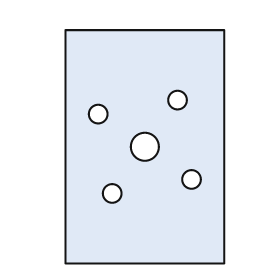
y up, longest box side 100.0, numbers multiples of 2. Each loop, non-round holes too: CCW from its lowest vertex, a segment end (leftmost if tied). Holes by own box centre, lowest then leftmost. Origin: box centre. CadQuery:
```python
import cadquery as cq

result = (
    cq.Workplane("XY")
    .moveTo(-34.0, -50.0)
    .lineTo(34.0, -50.0)
    .lineTo(34.0, 50.0)
    .lineTo(-34.0, 50.0)
    .close()
    .moveTo(-14.0, -20.0)
    .circle(4.0)
    .moveTo(20.0, -14.0)
    .circle(4.0)
    .moveTo(0.0, 0.0)
    .circle(6.0)
    .moveTo(-20.0, 14.0)
    .circle(4.0)
    .moveTo(14.0, 20.0)
    .circle(4.0)
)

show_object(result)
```